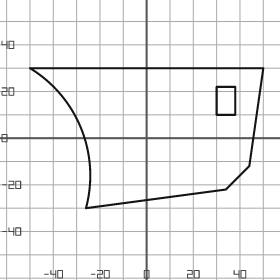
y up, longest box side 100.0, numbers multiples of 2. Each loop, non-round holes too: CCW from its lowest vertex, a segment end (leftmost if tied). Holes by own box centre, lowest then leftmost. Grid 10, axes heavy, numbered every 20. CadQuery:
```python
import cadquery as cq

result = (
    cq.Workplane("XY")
    .moveTo(-26.0, -30.0)
    .lineTo(34.0, -22.0)
    .lineTo(44.0, -12.0)
    .lineTo(50.0, 30.0)
    .lineTo(-50.0, 30.0)
    .threePointArc((-28.0, 4.0), (-26.0, -30.0))
    .close()
    .moveTo(30.0, 10.0)
    .lineTo(38.0, 10.0)
    .lineTo(38.0, 22.0)
    .lineTo(30.0, 22.0)
    .close()
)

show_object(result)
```